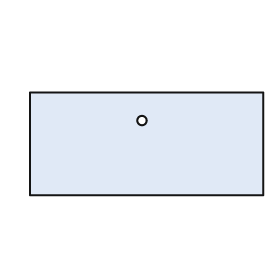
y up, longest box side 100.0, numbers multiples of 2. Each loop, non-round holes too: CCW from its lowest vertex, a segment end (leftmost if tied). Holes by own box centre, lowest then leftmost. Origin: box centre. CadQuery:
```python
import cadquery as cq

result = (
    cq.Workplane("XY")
    .moveTo(-50.0, -22.0)
    .lineTo(50.0, -22.0)
    .lineTo(50.0, 22.0)
    .lineTo(-50.0, 22.0)
    .close()
    .moveTo(-2.0, 10.0)
    .circle(2.0)
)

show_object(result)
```